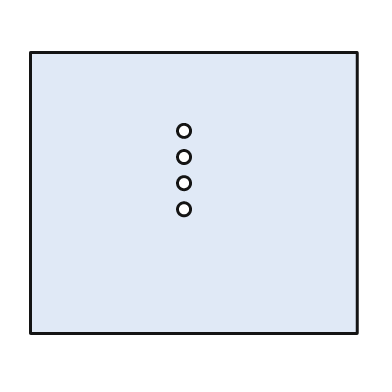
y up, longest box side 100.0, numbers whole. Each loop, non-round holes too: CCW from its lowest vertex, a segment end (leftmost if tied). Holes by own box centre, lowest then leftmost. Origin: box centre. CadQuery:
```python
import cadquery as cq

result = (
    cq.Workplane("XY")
    .moveTo(-50.0, -43.0)
    .lineTo(50.0, -43.0)
    .lineTo(50.0, 43.0)
    .lineTo(-50.0, 43.0)
    .close()
    .moveTo(-3.0, -5.0)
    .circle(2.0)
    .moveTo(-3.0, 3.0)
    .circle(2.0)
    .moveTo(-3.0, 11.0)
    .circle(2.0)
    .moveTo(-3.0, 19.0)
    .circle(2.0)
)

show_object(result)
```